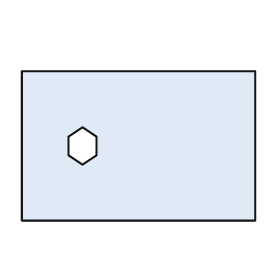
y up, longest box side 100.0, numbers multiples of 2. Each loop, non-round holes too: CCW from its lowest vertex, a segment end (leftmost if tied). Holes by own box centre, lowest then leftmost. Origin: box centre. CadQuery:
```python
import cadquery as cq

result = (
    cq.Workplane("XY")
    .moveTo(-50.0, -32.0)
    .lineTo(50.0, -32.0)
    .lineTo(50.0, 32.0)
    .lineTo(-50.0, 32.0)
    .close()
    .moveTo(-24.0, -8.0)
    .lineTo(-18.0, -4.0)
    .lineTo(-18.0, 4.0)
    .lineTo(-24.0, 8.0)
    .lineTo(-30.0, 4.0)
    .lineTo(-30.0, -4.0)
    .close()
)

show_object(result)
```